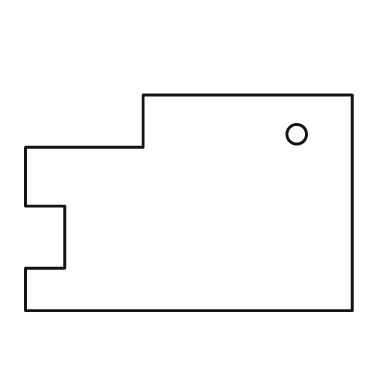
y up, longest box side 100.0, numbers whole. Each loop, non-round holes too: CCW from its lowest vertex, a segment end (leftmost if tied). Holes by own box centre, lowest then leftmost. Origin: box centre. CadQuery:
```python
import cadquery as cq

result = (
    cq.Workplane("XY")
    .moveTo(-50.0, -33.0)
    .lineTo(50.0, -33.0)
    .lineTo(50.0, 33.0)
    .lineTo(-14.0, 33.0)
    .lineTo(-14.0, 17.0)
    .lineTo(-50.0, 17.0)
    .lineTo(-50.0, -1.0)
    .lineTo(-38.0, -1.0)
    .lineTo(-38.0, -20.0)
    .lineTo(-50.0, -20.0)
    .close()
    .moveTo(33.0, 21.0)
    .circle(3.0)
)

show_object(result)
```